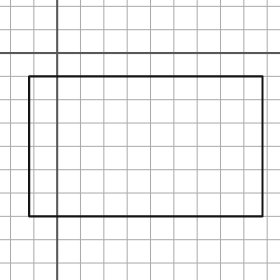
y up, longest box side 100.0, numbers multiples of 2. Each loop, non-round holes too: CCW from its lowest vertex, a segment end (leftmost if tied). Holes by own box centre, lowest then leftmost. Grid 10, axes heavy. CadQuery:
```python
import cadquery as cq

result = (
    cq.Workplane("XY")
    .moveTo(-12.0, -70.0)
    .lineTo(88.0, -70.0)
    .lineTo(88.0, -10.0)
    .lineTo(-12.0, -10.0)
    .close()
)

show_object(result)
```